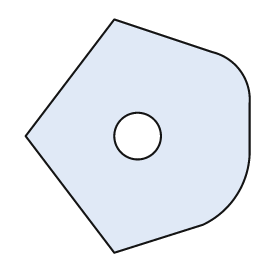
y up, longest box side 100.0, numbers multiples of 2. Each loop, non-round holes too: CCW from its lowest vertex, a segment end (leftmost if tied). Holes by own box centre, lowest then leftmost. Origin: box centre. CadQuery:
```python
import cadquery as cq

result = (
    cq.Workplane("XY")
    .moveTo(-10.0, -50.0)
    .lineTo(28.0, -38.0)
    .threePointArc((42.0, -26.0), (48.0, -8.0))
    .lineTo(48.0, 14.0)
    .threePointArc((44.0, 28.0), (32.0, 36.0))
    .lineTo(-10.0, 50.0)
    .lineTo(-48.0, 0.0)
    .close()
    .moveTo(0.0, 0.0)
    .circle(10.0)
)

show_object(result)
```